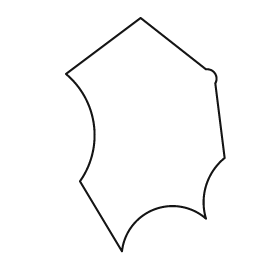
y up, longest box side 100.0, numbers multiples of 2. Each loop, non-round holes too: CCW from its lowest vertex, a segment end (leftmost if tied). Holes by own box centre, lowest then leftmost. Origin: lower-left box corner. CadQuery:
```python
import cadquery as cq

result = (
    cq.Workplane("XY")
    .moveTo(24.0, 0.0)
    .threePointArc((38.0, 18.0), (60.0, 14.0))
    .threePointArc((60.0, 28.0), (68.0, 40.0))
    .lineTo(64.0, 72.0)
    .threePointArc((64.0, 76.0), (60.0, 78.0))
    .lineTo(32.0, 100.0)
    .lineTo(0.0, 76.0)
    .threePointArc((12.0, 54.0), (6.0, 30.0))
    .close()
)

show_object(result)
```